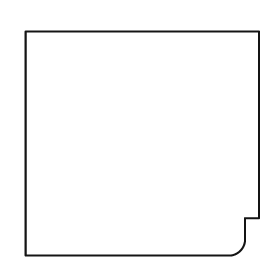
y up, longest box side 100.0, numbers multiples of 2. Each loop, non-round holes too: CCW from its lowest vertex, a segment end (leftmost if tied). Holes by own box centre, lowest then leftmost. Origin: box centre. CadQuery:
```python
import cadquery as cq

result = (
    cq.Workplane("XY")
    .moveTo(-50.0, -48.0)
    .lineTo(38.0, -48.0)
    .threePointArc((42.0, -46.0), (44.0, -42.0))
    .lineTo(44.0, -32.0)
    .lineTo(50.0, -32.0)
    .lineTo(50.0, 48.0)
    .lineTo(-50.0, 48.0)
    .close()
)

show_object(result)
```